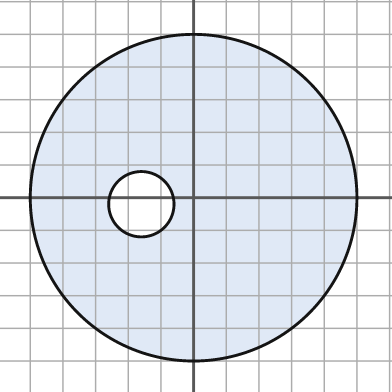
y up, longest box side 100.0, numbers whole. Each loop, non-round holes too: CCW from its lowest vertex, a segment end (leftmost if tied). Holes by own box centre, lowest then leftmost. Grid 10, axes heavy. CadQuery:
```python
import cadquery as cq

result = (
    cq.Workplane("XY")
    .moveTo(0.0, 0.0)
    .circle(50.0)
    .moveTo(-16.0, -2.0)
    .circle(10.0)
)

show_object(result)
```